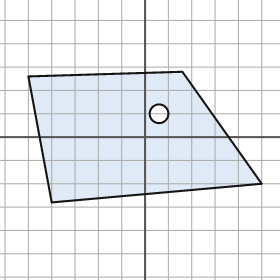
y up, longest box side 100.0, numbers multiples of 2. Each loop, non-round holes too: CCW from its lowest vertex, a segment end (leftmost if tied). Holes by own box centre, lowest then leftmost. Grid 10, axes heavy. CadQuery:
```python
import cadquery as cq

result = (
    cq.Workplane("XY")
    .moveTo(-40.0, -28.0)
    .lineTo(50.0, -20.0)
    .lineTo(16.0, 28.0)
    .lineTo(-50.0, 26.0)
    .close()
    .moveTo(6.0, 10.0)
    .circle(4.0)
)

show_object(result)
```